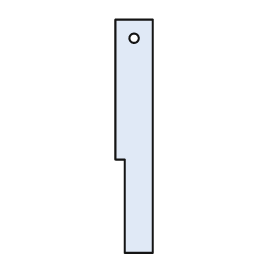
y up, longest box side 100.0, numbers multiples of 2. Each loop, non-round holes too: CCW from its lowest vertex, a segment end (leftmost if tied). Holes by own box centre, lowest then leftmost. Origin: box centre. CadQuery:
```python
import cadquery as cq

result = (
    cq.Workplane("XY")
    .moveTo(-4.0, -50.0)
    .lineTo(8.0, -50.0)
    .lineTo(8.0, 50.0)
    .lineTo(-8.0, 50.0)
    .lineTo(-8.0, -10.0)
    .lineTo(-4.0, -10.0)
    .close()
    .moveTo(0.0, 42.0)
    .circle(2.0)
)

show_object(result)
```